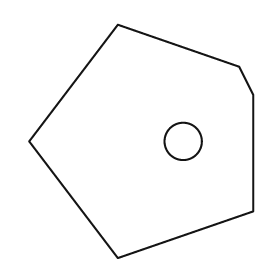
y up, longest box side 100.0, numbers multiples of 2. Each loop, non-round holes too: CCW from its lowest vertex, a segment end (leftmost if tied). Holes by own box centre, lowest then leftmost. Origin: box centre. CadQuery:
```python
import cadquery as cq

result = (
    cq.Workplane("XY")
    .moveTo(-10.0, -50.0)
    .lineTo(48.0, -30.0)
    .lineTo(48.0, 20.0)
    .lineTo(42.0, 32.0)
    .lineTo(-10.0, 50.0)
    .lineTo(-48.0, 0.0)
    .close()
    .moveTo(18.0, 0.0)
    .circle(8.0)
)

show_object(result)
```